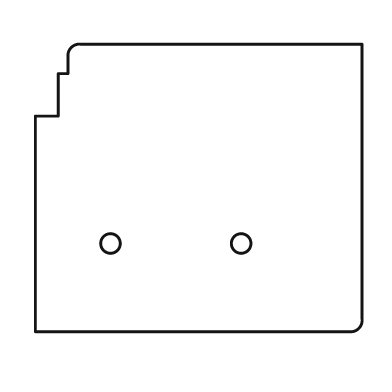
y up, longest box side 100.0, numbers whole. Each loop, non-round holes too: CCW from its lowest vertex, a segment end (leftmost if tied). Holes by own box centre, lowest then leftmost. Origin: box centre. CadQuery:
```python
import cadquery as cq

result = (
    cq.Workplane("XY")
    .moveTo(-50.0, -44.0)
    .lineTo(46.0, -44.0)
    .threePointArc((49.0, -43.0), (50.0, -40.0))
    .lineTo(50.0, 44.0)
    .lineTo(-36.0, 44.0)
    .threePointArc((-39.0, 43.0), (-40.0, 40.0))
    .lineTo(-40.0, 35.0)
    .lineTo(-43.0, 35.0)
    .lineTo(-43.0, 22.0)
    .lineTo(-50.0, 22.0)
    .close()
    .moveTo(-27.0, -17.0)
    .circle(3.0)
    .moveTo(13.0, -17.0)
    .circle(3.0)
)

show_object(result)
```